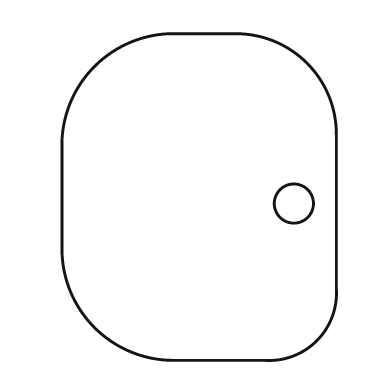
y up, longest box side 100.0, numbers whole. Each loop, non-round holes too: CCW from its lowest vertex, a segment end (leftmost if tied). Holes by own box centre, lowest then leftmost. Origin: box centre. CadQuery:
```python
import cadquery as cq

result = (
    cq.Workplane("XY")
    .moveTo(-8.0, -50.0)
    .lineTo(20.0, -50.0)
    .threePointArc((36.0, -44.0), (42.0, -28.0))
    .lineTo(42.0, 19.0)
    .threePointArc((33.0, 41.0), (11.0, 50.0))
    .lineTo(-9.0, 50.0)
    .threePointArc((-32.0, 40.0), (-42.0, 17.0))
    .lineTo(-42.0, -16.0)
    .threePointArc((-32.0, -40.0), (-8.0, -50.0))
    .close()
    .moveTo(29.0, -2.0)
    .circle(6.0)
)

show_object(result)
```